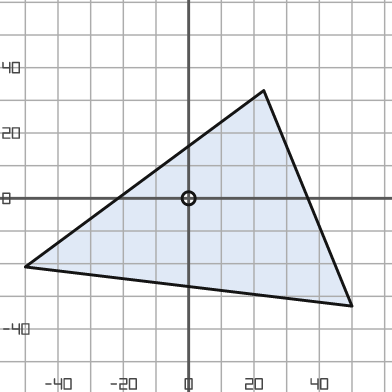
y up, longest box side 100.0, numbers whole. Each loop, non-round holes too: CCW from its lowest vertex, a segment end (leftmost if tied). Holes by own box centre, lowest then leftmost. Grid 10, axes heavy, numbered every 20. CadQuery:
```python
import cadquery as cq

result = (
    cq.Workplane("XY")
    .moveTo(50.0, -33.0)
    .lineTo(23.0, 33.0)
    .lineTo(-50.0, -21.0)
    .close()
    .moveTo(0.0, 0.0)
    .circle(2.0)
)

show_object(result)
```